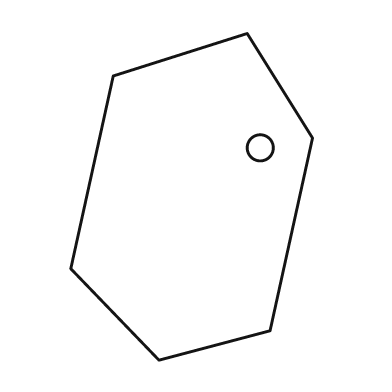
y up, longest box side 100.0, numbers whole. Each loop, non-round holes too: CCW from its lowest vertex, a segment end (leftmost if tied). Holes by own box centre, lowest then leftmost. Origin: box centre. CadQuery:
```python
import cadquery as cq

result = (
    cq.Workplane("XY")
    .moveTo(-10.0, -50.0)
    .lineTo(24.0, -41.0)
    .lineTo(37.0, 18.0)
    .lineTo(17.0, 50.0)
    .lineTo(-24.0, 37.0)
    .lineTo(-37.0, -22.0)
    .close()
    .moveTo(21.0, 15.0)
    .circle(4.0)
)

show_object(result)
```